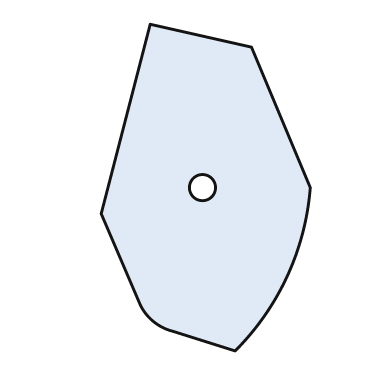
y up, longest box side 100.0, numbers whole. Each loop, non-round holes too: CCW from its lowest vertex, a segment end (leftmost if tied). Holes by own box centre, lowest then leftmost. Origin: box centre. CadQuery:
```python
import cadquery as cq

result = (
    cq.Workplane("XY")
    .moveTo(9.0, -50.0)
    .threePointArc((25.0, -27.0), (32.0, 0.0))
    .lineTo(14.0, 43.0)
    .lineTo(-17.0, 50.0)
    .lineTo(-32.0, -8.0)
    .lineTo(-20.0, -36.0)
    .threePointArc((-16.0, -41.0), (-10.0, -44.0))
    .close()
    .moveTo(-1.0, 0.0)
    .circle(4.0)
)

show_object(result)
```